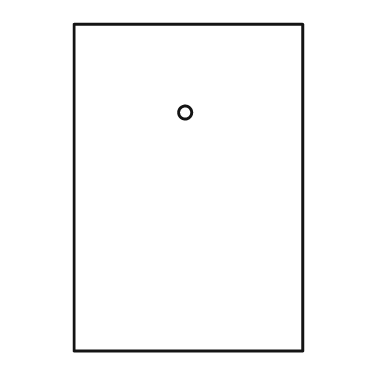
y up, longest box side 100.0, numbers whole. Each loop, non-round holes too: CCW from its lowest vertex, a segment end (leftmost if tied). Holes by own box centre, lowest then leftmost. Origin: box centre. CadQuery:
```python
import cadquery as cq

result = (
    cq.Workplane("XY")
    .moveTo(-35.0, -50.0)
    .lineTo(35.0, -50.0)
    .lineTo(35.0, 50.0)
    .lineTo(-35.0, 50.0)
    .close()
    .moveTo(-1.0, 23.0)
    .circle(2.0)
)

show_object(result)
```